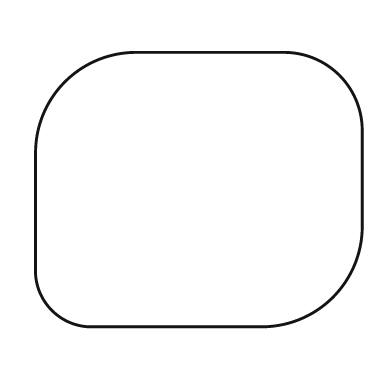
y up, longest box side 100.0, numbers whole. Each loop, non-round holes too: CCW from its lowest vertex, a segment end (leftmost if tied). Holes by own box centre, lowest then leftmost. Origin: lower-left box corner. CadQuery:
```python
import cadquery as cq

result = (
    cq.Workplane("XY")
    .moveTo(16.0, 0.0)
    .lineTo(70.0, 0.0)
    .threePointArc((91.0, 9.0), (100.0, 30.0))
    .lineTo(100.0, 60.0)
    .threePointArc((93.0, 77.0), (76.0, 84.0))
    .lineTo(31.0, 84.0)
    .threePointArc((9.0, 75.0), (0.0, 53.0))
    .lineTo(0.0, 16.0)
    .threePointArc((5.0, 5.0), (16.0, 0.0))
    .close()
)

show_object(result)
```